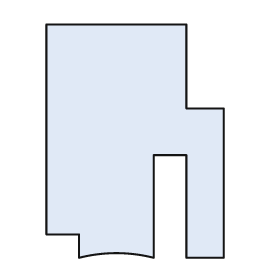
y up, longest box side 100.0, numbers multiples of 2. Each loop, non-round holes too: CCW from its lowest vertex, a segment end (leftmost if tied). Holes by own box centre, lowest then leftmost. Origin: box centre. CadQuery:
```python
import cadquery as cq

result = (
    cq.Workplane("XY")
    .moveTo(-24.0, -50.0)
    .threePointArc((-8.0, -48.0), (8.0, -50.0))
    .lineTo(8.0, -6.0)
    .lineTo(22.0, -6.0)
    .lineTo(22.0, -50.0)
    .lineTo(38.0, -50.0)
    .lineTo(38.0, 14.0)
    .lineTo(22.0, 14.0)
    .lineTo(22.0, 50.0)
    .lineTo(-38.0, 50.0)
    .lineTo(-38.0, -40.0)
    .lineTo(-24.0, -40.0)
    .close()
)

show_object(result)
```